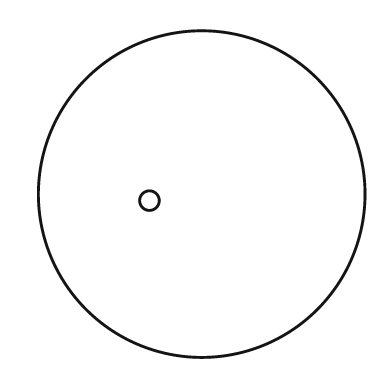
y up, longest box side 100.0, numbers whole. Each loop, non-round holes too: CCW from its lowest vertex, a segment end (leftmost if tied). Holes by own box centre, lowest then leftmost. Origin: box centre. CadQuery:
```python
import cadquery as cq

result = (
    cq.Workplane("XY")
    .moveTo(0.0, 0.0)
    .circle(50.0)
    .moveTo(-16.0, -2.0)
    .circle(3.0)
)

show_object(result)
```